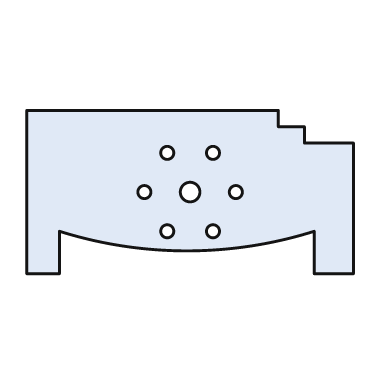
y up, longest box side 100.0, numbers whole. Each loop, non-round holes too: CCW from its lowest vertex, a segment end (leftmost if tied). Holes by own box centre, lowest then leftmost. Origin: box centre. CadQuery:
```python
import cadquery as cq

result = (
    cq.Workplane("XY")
    .moveTo(-50.0, -25.0)
    .lineTo(-40.0, -25.0)
    .lineTo(-40.0, -12.0)
    .threePointArc((-1.0, -18.0), (38.0, -12.0))
    .lineTo(38.0, -25.0)
    .lineTo(50.0, -25.0)
    .lineTo(50.0, 15.0)
    .lineTo(35.0, 15.0)
    .lineTo(35.0, 20.0)
    .lineTo(27.0, 20.0)
    .lineTo(27.0, 25.0)
    .lineTo(-50.0, 25.0)
    .close()
    .moveTo(-7.0, -12.0)
    .circle(2.0)
    .moveTo(7.0, -12.0)
    .circle(2.0)
    .moveTo(-14.0, 0.0)
    .circle(2.0)
    .moveTo(0.0, 0.0)
    .circle(3.0)
    .moveTo(14.0, 0.0)
    .circle(2.0)
    .moveTo(-7.0, 12.0)
    .circle(2.0)
    .moveTo(7.0, 12.0)
    .circle(2.0)
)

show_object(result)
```